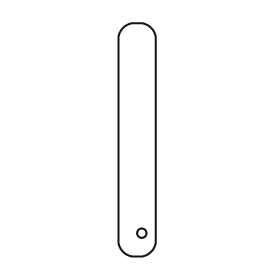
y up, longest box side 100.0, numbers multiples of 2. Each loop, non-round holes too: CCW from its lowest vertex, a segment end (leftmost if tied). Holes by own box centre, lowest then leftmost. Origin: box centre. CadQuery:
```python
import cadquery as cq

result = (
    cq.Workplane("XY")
    .moveTo(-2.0, -50.0)
    .lineTo(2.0, -50.0)
    .threePointArc((6.0, -48.0), (8.0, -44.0))
    .lineTo(8.0, 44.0)
    .threePointArc((6.0, 48.0), (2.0, 50.0))
    .lineTo(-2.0, 50.0)
    .threePointArc((-6.0, 48.0), (-8.0, 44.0))
    .lineTo(-8.0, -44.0)
    .threePointArc((-6.0, -48.0), (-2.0, -50.0))
    .close()
    .moveTo(2.0, -40.0)
    .circle(2.0)
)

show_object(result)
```